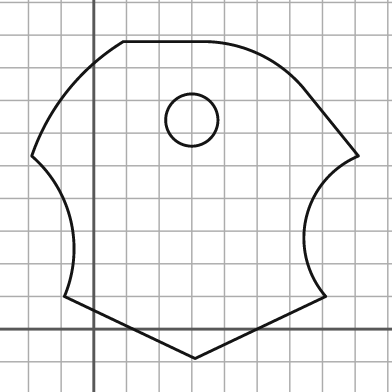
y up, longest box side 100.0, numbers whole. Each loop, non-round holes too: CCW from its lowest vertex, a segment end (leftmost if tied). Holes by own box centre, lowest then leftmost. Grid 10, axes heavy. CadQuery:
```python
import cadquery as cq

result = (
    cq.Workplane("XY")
    .moveTo(31.0, -9.0)
    .lineTo(71.0, 10.0)
    .threePointArc((65.0, 34.0), (81.0, 53.0))
    .lineTo(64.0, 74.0)
    .threePointArc((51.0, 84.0), (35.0, 88.0))
    .lineTo(9.0, 88.0)
    .threePointArc((-8.0, 73.0), (-19.0, 53.0))
    .threePointArc((-7.0, 33.0), (-9.0, 10.0))
    .close()
    .moveTo(30.0, 64.0)
    .circle(8.0)
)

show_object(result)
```